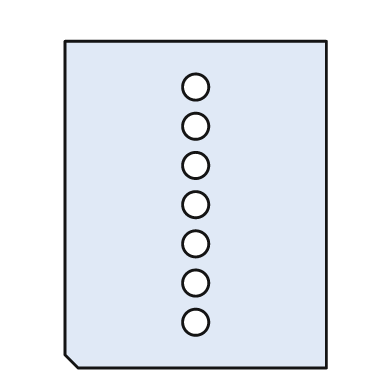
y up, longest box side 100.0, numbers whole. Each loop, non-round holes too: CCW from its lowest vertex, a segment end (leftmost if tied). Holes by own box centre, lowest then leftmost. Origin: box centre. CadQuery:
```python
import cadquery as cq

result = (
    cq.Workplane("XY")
    .moveTo(-36.0, -50.0)
    .lineTo(40.0, -50.0)
    .lineTo(40.0, 50.0)
    .lineTo(-40.0, 50.0)
    .lineTo(-40.0, -46.0)
    .close()
    .moveTo(0.0, -36.0)
    .circle(4.0)
    .moveTo(0.0, -24.0)
    .circle(4.0)
    .moveTo(0.0, -12.0)
    .circle(4.0)
    .moveTo(0.0, 0.0)
    .circle(4.0)
    .moveTo(0.0, 12.0)
    .circle(4.0)
    .moveTo(0.0, 24.0)
    .circle(4.0)
    .moveTo(0.0, 36.0)
    .circle(4.0)
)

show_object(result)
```